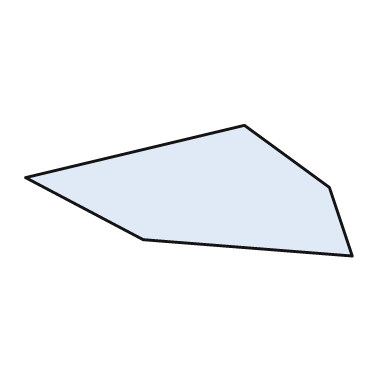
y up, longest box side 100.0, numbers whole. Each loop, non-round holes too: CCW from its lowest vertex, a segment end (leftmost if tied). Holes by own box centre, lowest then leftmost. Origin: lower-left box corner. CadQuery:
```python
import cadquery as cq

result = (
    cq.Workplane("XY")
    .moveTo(100.0, 0.0)
    .lineTo(93.0, 21.0)
    .lineTo(67.0, 40.0)
    .lineTo(0.0, 24.0)
    .lineTo(36.0, 5.0)
    .close()
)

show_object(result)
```